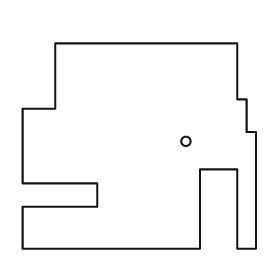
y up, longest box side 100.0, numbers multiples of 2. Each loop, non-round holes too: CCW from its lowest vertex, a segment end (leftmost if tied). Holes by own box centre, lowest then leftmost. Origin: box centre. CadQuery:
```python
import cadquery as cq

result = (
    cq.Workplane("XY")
    .moveTo(-50.0, -44.0)
    .lineTo(26.0, -44.0)
    .lineTo(26.0, -10.0)
    .lineTo(42.0, -10.0)
    .lineTo(42.0, -44.0)
    .lineTo(50.0, -44.0)
    .lineTo(50.0, 6.0)
    .lineTo(46.0, 6.0)
    .lineTo(46.0, 20.0)
    .lineTo(42.0, 20.0)
    .lineTo(42.0, 44.0)
    .lineTo(-36.0, 44.0)
    .lineTo(-36.0, 16.0)
    .lineTo(-50.0, 16.0)
    .lineTo(-50.0, -16.0)
    .lineTo(-18.0, -16.0)
    .lineTo(-18.0, -26.0)
    .lineTo(-50.0, -26.0)
    .close()
    .moveTo(20.0, 2.0)
    .circle(2.0)
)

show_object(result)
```